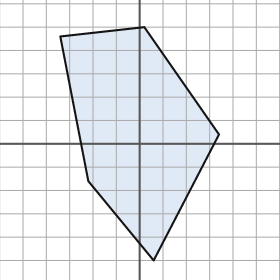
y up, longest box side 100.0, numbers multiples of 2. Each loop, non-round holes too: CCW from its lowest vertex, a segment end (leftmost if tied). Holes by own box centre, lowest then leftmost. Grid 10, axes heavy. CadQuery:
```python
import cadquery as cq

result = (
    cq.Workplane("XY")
    .moveTo(6.0, -50.0)
    .lineTo(34.0, 4.0)
    .lineTo(2.0, 50.0)
    .lineTo(-34.0, 46.0)
    .lineTo(-22.0, -16.0)
    .close()
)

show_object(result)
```